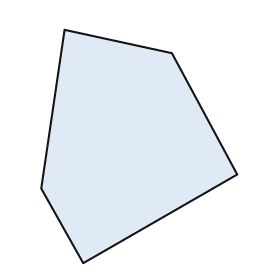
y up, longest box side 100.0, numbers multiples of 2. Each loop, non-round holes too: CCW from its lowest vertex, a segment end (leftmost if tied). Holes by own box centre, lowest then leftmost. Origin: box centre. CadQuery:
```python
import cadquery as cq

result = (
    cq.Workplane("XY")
    .moveTo(-24.0, -50.0)
    .lineTo(42.0, -12.0)
    .lineTo(14.0, 40.0)
    .lineTo(-32.0, 50.0)
    .lineTo(-42.0, -18.0)
    .close()
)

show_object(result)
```